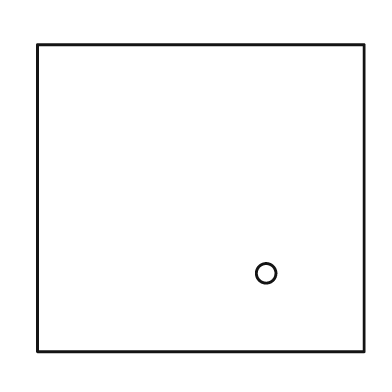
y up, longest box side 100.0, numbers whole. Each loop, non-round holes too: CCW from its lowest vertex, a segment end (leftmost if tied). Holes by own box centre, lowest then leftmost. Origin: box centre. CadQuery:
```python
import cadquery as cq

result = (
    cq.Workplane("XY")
    .moveTo(-50.0, -47.0)
    .lineTo(50.0, -47.0)
    .lineTo(50.0, 47.0)
    .lineTo(-50.0, 47.0)
    .close()
    .moveTo(20.0, -23.0)
    .circle(3.0)
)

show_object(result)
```